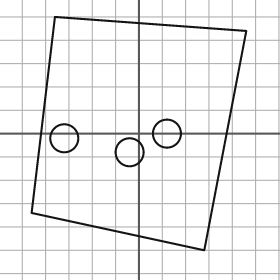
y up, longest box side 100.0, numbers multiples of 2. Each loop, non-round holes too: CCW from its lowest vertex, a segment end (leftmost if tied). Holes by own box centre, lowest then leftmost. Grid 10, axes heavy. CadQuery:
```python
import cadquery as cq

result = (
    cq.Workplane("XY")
    .moveTo(28.0, -50.0)
    .lineTo(46.0, 44.0)
    .lineTo(-36.0, 50.0)
    .lineTo(-46.0, -34.0)
    .close()
    .moveTo(-4.0, -8.0)
    .circle(6.0)
    .moveTo(-32.0, -2.0)
    .circle(6.0)
    .moveTo(12.0, 0.0)
    .circle(6.0)
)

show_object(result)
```